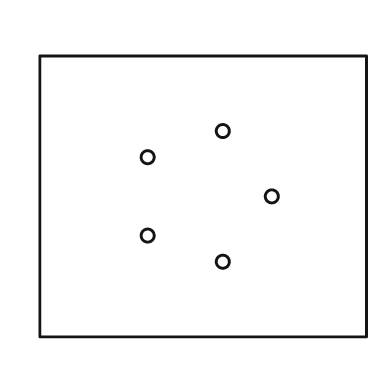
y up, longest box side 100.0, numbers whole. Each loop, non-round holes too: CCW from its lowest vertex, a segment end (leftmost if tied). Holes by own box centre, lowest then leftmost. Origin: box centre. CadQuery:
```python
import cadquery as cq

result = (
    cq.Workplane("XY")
    .moveTo(-50.0, -43.0)
    .lineTo(50.0, -43.0)
    .lineTo(50.0, 43.0)
    .lineTo(-50.0, 43.0)
    .close()
    .moveTo(6.0, -20.0)
    .circle(2.0)
    .moveTo(-17.0, -12.0)
    .circle(2.0)
    .moveTo(21.0, 0.0)
    .circle(2.0)
    .moveTo(-17.0, 12.0)
    .circle(2.0)
    .moveTo(6.0, 20.0)
    .circle(2.0)
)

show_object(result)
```